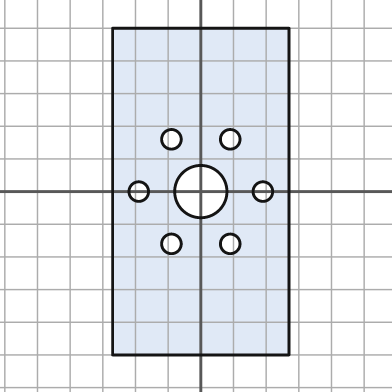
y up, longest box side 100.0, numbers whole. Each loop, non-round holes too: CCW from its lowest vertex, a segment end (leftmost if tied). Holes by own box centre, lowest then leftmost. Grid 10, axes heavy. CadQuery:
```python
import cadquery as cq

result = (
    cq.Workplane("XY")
    .moveTo(-27.0, -50.0)
    .lineTo(27.0, -50.0)
    .lineTo(27.0, 50.0)
    .lineTo(-27.0, 50.0)
    .close()
    .moveTo(-9.0, -16.0)
    .circle(3.0)
    .moveTo(9.0, -16.0)
    .circle(3.0)
    .moveTo(-19.0, 0.0)
    .circle(3.0)
    .moveTo(0.0, 0.0)
    .circle(8.0)
    .moveTo(19.0, 0.0)
    .circle(3.0)
    .moveTo(-9.0, 16.0)
    .circle(3.0)
    .moveTo(9.0, 16.0)
    .circle(3.0)
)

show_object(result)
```